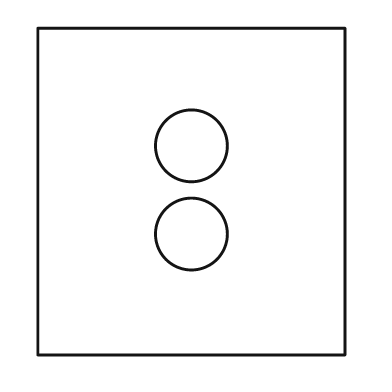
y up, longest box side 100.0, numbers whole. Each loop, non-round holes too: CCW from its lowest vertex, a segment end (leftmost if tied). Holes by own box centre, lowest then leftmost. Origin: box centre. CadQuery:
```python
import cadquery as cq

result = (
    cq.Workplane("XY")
    .moveTo(-47.0, -50.0)
    .lineTo(47.0, -50.0)
    .lineTo(47.0, 50.0)
    .lineTo(-47.0, 50.0)
    .close()
    .moveTo(0.0, -13.0)
    .circle(11.0)
    .moveTo(0.0, 14.0)
    .circle(11.0)
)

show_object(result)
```